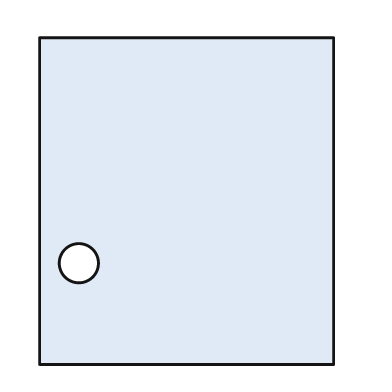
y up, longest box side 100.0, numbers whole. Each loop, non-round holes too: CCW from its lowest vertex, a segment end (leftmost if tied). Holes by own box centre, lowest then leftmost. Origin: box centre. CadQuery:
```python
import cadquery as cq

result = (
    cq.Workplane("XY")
    .moveTo(-45.0, -50.0)
    .lineTo(45.0, -50.0)
    .lineTo(45.0, 50.0)
    .lineTo(-45.0, 50.0)
    .close()
    .moveTo(-33.0, -19.0)
    .circle(6.0)
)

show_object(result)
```